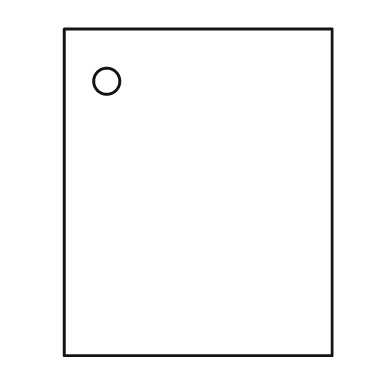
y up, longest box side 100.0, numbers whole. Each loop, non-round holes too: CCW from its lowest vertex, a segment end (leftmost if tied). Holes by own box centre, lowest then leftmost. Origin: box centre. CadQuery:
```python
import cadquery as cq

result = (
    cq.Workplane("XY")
    .moveTo(-41.0, -50.0)
    .lineTo(41.0, -50.0)
    .lineTo(41.0, 50.0)
    .lineTo(-41.0, 50.0)
    .close()
    .moveTo(-28.0, 34.0)
    .circle(4.0)
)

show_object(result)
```